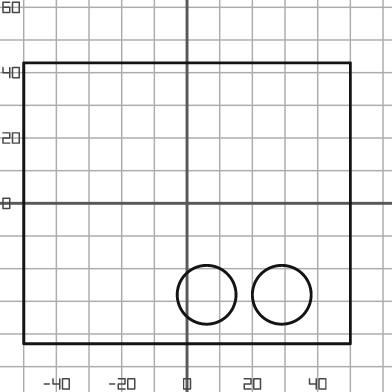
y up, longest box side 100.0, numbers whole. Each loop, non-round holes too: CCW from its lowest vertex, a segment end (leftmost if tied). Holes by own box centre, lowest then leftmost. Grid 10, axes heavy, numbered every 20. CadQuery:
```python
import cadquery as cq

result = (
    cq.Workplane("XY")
    .moveTo(-50.0, -43.0)
    .lineTo(50.0, -43.0)
    .lineTo(50.0, 43.0)
    .lineTo(-50.0, 43.0)
    .close()
    .moveTo(6.0, -28.0)
    .circle(9.0)
    .moveTo(29.0, -28.0)
    .circle(9.0)
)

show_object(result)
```